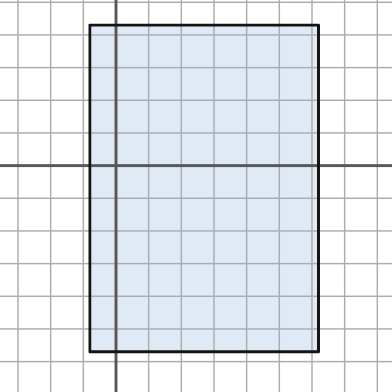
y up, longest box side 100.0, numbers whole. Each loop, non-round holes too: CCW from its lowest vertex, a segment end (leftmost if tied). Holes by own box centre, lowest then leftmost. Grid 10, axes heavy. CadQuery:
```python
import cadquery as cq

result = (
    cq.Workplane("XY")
    .moveTo(-8.0, -57.0)
    .lineTo(62.0, -57.0)
    .lineTo(62.0, 43.0)
    .lineTo(-8.0, 43.0)
    .close()
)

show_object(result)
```